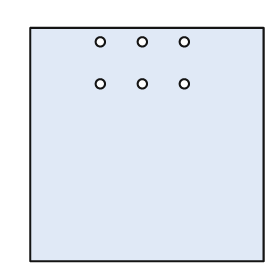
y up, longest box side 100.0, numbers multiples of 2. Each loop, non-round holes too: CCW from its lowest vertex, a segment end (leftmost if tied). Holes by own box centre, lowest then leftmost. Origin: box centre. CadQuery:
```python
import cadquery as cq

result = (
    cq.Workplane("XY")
    .moveTo(-50.0, -50.0)
    .lineTo(50.0, -50.0)
    .lineTo(50.0, 50.0)
    .lineTo(-50.0, 50.0)
    .close()
    .moveTo(-20.0, 26.0)
    .circle(2.0)
    .moveTo(-2.0, 26.0)
    .circle(2.0)
    .moveTo(16.0, 26.0)
    .circle(2.0)
    .moveTo(-20.0, 44.0)
    .circle(2.0)
    .moveTo(-2.0, 44.0)
    .circle(2.0)
    .moveTo(16.0, 44.0)
    .circle(2.0)
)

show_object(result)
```